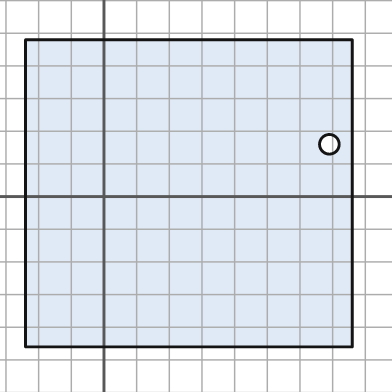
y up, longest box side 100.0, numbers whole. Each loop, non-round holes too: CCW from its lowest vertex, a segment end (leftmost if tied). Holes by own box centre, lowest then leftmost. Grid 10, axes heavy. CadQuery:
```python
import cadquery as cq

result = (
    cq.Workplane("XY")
    .moveTo(-24.0, -46.0)
    .lineTo(76.0, -46.0)
    .lineTo(76.0, 48.0)
    .lineTo(-24.0, 48.0)
    .close()
    .moveTo(69.0, 16.0)
    .circle(3.0)
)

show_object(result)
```